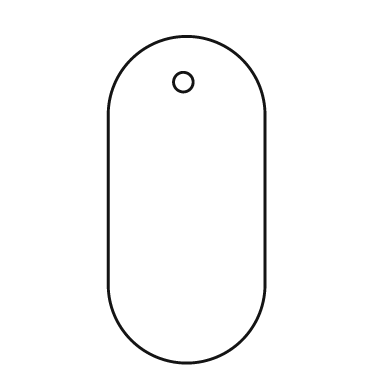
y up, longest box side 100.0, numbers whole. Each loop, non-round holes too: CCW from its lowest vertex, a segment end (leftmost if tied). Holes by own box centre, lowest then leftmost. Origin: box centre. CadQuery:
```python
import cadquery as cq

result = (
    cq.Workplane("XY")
    .moveTo(-24.0, -26.0)
    .threePointArc((0.0, -50.0), (24.0, -26.0))
    .lineTo(24.0, 26.0)
    .threePointArc((0.0, 50.0), (-24.0, 26.0))
    .close()
    .moveTo(-1.0, 36.0)
    .circle(3.0)
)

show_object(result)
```